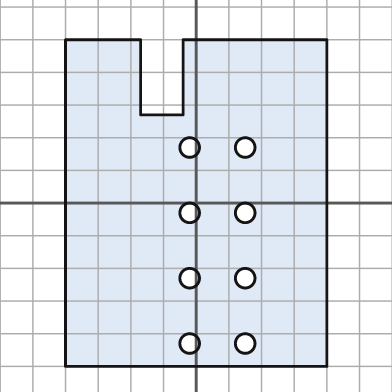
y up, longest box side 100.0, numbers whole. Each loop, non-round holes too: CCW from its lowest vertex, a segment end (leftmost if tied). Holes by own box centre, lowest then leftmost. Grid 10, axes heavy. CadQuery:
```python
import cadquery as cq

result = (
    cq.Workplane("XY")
    .moveTo(-40.0, -50.0)
    .lineTo(40.0, -50.0)
    .lineTo(40.0, 50.0)
    .lineTo(-4.0, 50.0)
    .lineTo(-4.0, 27.0)
    .lineTo(-17.0, 27.0)
    .lineTo(-17.0, 50.0)
    .lineTo(-40.0, 50.0)
    .close()
    .moveTo(-2.0, -43.0)
    .circle(3.0)
    .moveTo(15.0, -43.0)
    .circle(3.0)
    .moveTo(-2.0, -23.0)
    .circle(3.0)
    .moveTo(15.0, -23.0)
    .circle(3.0)
    .moveTo(-2.0, -3.0)
    .circle(3.0)
    .moveTo(15.0, -3.0)
    .circle(3.0)
    .moveTo(-2.0, 17.0)
    .circle(3.0)
    .moveTo(15.0, 17.0)
    .circle(3.0)
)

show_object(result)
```